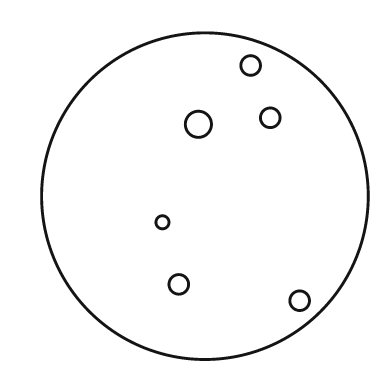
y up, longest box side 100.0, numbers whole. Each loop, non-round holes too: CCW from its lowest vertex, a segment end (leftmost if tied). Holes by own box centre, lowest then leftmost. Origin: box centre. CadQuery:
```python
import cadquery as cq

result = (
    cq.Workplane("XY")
    .moveTo(0.0, 0.0)
    .circle(50.0)
    .moveTo(29.0, -32.0)
    .circle(3.0)
    .moveTo(-8.0, -27.0)
    .circle(3.0)
    .moveTo(-13.0, -8.0)
    .circle(2.0)
    .moveTo(-2.0, 22.0)
    .circle(4.0)
    .moveTo(20.0, 24.0)
    .circle(3.0)
    .moveTo(14.0, 40.0)
    .circle(3.0)
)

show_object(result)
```